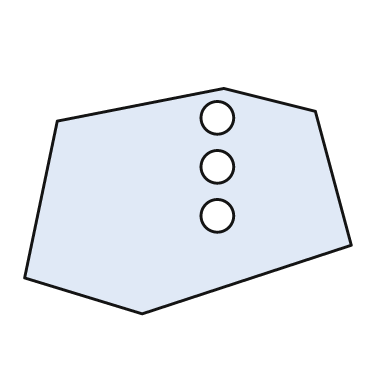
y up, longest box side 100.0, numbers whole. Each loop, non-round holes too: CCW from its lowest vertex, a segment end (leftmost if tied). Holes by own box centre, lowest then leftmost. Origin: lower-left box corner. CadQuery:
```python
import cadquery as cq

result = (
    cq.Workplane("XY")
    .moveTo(36.0, 0.0)
    .lineTo(100.0, 21.0)
    .lineTo(89.0, 62.0)
    .lineTo(61.0, 69.0)
    .lineTo(10.0, 59.0)
    .lineTo(0.0, 11.0)
    .close()
    .moveTo(59.0, 30.0)
    .circle(5.0)
    .moveTo(59.0, 45.0)
    .circle(5.0)
    .moveTo(59.0, 60.0)
    .circle(5.0)
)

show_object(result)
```